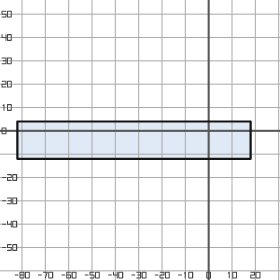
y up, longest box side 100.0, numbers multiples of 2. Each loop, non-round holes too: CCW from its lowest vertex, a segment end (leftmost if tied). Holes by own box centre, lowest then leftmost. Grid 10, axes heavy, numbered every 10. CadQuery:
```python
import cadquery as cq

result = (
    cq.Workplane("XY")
    .moveTo(-82.0, -12.0)
    .lineTo(18.0, -12.0)
    .lineTo(18.0, 4.0)
    .lineTo(-82.0, 4.0)
    .close()
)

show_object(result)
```